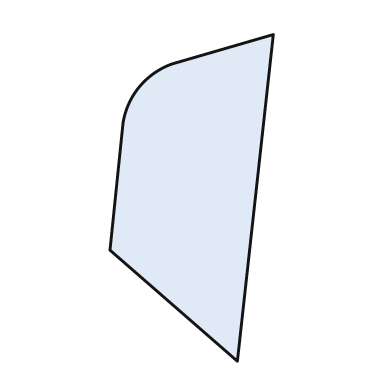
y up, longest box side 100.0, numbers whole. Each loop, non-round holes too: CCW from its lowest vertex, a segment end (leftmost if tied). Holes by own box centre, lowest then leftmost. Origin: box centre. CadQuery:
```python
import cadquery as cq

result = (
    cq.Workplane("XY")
    .moveTo(14.0, -50.0)
    .lineTo(25.0, 50.0)
    .lineTo(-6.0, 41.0)
    .threePointArc((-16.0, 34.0), (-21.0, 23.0))
    .lineTo(-25.0, -16.0)
    .close()
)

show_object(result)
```